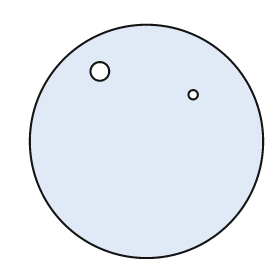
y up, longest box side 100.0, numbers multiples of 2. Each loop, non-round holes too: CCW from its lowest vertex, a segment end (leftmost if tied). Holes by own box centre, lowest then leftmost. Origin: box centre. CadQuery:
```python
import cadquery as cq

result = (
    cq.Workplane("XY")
    .moveTo(0.0, 0.0)
    .circle(50.0)
    .moveTo(20.0, 20.0)
    .circle(2.0)
    .moveTo(-20.0, 30.0)
    .circle(4.0)
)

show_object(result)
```